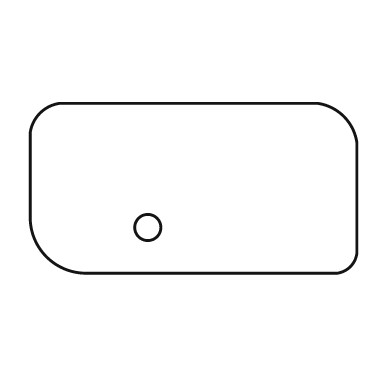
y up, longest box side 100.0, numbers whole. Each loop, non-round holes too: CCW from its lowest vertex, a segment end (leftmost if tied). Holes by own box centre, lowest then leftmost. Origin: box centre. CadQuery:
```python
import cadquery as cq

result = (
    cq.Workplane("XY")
    .moveTo(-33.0, -26.0)
    .lineTo(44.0, -26.0)
    .threePointArc((48.0, -24.0), (50.0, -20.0))
    .lineTo(50.0, 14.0)
    .threePointArc((46.0, 22.0), (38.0, 26.0))
    .lineTo(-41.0, 26.0)
    .threePointArc((-47.0, 23.0), (-50.0, 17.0))
    .lineTo(-50.0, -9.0)
    .threePointArc((-45.0, -21.0), (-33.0, -26.0))
    .close()
    .moveTo(-14.0, -12.0)
    .circle(4.0)
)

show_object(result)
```